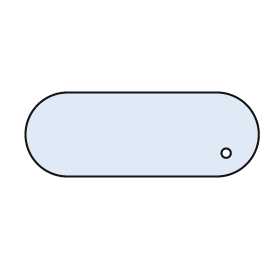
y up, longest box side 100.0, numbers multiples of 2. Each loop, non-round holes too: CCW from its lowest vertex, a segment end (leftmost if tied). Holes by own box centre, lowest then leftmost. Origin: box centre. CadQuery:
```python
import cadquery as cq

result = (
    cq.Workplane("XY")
    .moveTo(-32.0, -18.0)
    .lineTo(32.0, -18.0)
    .threePointArc((50.0, 0.0), (32.0, 18.0))
    .lineTo(-32.0, 18.0)
    .threePointArc((-50.0, 0.0), (-32.0, -18.0))
    .close()
    .moveTo(36.0, -8.0)
    .circle(2.0)
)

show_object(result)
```